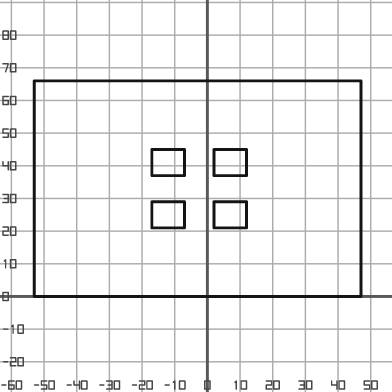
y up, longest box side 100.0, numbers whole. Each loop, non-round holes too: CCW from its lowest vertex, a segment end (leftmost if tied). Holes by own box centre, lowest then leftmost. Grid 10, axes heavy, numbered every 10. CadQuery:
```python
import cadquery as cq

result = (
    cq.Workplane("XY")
    .moveTo(-53.0, 0.0)
    .lineTo(47.0, 0.0)
    .lineTo(47.0, 66.0)
    .lineTo(-53.0, 66.0)
    .close()
    .moveTo(-17.0, 21.0)
    .lineTo(-7.0, 21.0)
    .lineTo(-7.0, 29.0)
    .lineTo(-17.0, 29.0)
    .close()
    .moveTo(2.0, 21.0)
    .lineTo(12.0, 21.0)
    .lineTo(12.0, 29.0)
    .lineTo(2.0, 29.0)
    .close()
    .moveTo(-17.0, 37.0)
    .lineTo(-7.0, 37.0)
    .lineTo(-7.0, 45.0)
    .lineTo(-17.0, 45.0)
    .close()
    .moveTo(2.0, 37.0)
    .lineTo(12.0, 37.0)
    .lineTo(12.0, 45.0)
    .lineTo(2.0, 45.0)
    .close()
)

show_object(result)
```